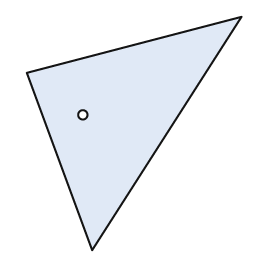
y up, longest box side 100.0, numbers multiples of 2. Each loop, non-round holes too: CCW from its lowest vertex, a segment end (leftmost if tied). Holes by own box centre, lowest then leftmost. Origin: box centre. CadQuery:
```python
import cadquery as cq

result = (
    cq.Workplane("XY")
    .moveTo(-18.0, -50.0)
    .lineTo(46.0, 50.0)
    .lineTo(-46.0, 26.0)
    .close()
    .moveTo(-22.0, 8.0)
    .circle(2.0)
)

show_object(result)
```